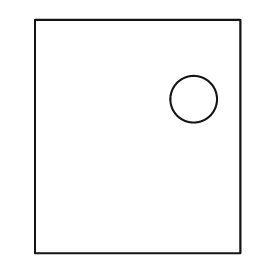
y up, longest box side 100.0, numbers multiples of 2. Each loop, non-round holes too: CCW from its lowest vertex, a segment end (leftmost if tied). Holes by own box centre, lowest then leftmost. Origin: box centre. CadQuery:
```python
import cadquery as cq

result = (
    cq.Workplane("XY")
    .moveTo(-44.0, -50.0)
    .lineTo(44.0, -50.0)
    .lineTo(44.0, 50.0)
    .lineTo(-44.0, 50.0)
    .close()
    .moveTo(24.0, 16.0)
    .circle(10.0)
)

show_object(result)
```